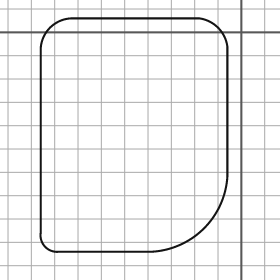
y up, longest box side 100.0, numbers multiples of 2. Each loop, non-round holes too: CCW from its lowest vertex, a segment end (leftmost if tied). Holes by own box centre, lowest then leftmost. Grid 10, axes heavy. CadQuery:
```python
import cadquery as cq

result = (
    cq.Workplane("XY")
    .moveTo(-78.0, -94.0)
    .lineTo(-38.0, -94.0)
    .threePointArc((-16.0, -84.0), (-6.0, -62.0))
    .lineTo(-6.0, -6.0)
    .threePointArc((-10.0, 2.0), (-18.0, 6.0))
    .lineTo(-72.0, 6.0)
    .threePointArc((-82.0, 2.0), (-86.0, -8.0))
    .lineTo(-86.0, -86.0)
    .threePointArc((-84.0, -92.0), (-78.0, -94.0))
    .close()
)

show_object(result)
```